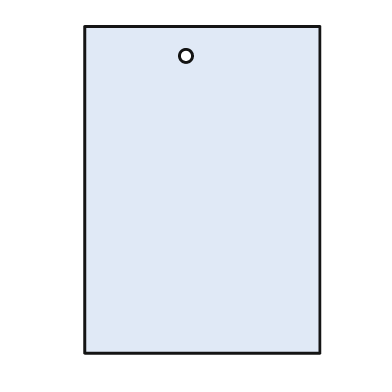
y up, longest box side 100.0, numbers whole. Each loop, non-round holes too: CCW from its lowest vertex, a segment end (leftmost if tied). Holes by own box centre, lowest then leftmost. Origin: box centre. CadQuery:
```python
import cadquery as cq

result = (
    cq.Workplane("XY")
    .moveTo(-36.0, -50.0)
    .lineTo(36.0, -50.0)
    .lineTo(36.0, 50.0)
    .lineTo(-36.0, 50.0)
    .close()
    .moveTo(-5.0, 41.0)
    .circle(2.0)
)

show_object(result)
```